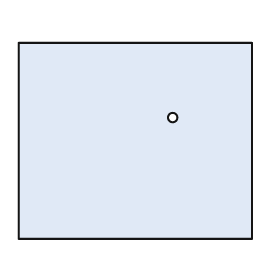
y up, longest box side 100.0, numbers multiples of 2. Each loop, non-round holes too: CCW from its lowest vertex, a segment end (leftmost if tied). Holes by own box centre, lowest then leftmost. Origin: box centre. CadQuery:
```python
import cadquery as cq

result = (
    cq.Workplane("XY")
    .moveTo(-50.0, -42.0)
    .lineTo(50.0, -42.0)
    .lineTo(50.0, 42.0)
    .lineTo(-50.0, 42.0)
    .close()
    .moveTo(16.0, 10.0)
    .circle(2.0)
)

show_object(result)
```